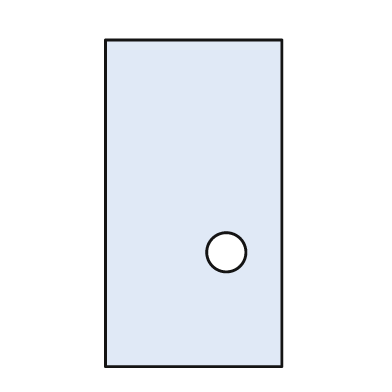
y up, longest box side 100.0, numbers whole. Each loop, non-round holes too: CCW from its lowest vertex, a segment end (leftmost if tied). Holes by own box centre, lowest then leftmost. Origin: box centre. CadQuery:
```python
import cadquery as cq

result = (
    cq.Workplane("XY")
    .moveTo(-27.0, -50.0)
    .lineTo(27.0, -50.0)
    .lineTo(27.0, 50.0)
    .lineTo(-27.0, 50.0)
    .close()
    .moveTo(10.0, -15.0)
    .circle(6.0)
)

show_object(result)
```